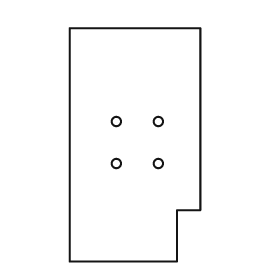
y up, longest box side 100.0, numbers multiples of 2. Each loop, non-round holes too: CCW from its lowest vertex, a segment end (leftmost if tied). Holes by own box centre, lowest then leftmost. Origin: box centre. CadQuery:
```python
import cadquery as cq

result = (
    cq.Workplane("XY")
    .moveTo(-28.0, -50.0)
    .lineTo(18.0, -50.0)
    .lineTo(18.0, -28.0)
    .lineTo(28.0, -28.0)
    .lineTo(28.0, 50.0)
    .lineTo(-28.0, 50.0)
    .close()
    .moveTo(-8.0, -8.0)
    .circle(2.0)
    .moveTo(10.0, -8.0)
    .circle(2.0)
    .moveTo(-8.0, 10.0)
    .circle(2.0)
    .moveTo(10.0, 10.0)
    .circle(2.0)
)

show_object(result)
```